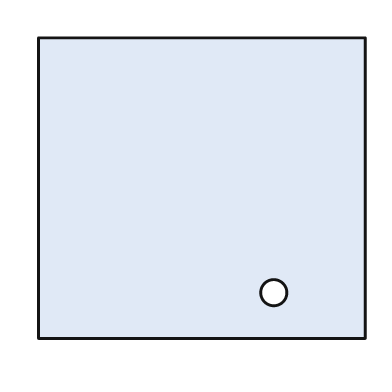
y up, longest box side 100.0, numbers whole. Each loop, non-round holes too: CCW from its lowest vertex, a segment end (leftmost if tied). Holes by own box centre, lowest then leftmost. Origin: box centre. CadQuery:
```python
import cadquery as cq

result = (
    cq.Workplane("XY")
    .moveTo(-50.0, -46.0)
    .lineTo(50.0, -46.0)
    .lineTo(50.0, 46.0)
    .lineTo(-50.0, 46.0)
    .close()
    .moveTo(22.0, -32.0)
    .circle(4.0)
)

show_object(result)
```